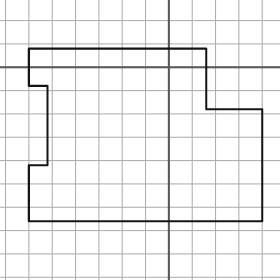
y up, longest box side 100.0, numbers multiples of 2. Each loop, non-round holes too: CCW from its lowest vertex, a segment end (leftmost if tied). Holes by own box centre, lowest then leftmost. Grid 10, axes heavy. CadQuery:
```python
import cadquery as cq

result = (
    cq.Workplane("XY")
    .moveTo(-60.0, -66.0)
    .lineTo(40.0, -66.0)
    .lineTo(40.0, -18.0)
    .lineTo(16.0, -18.0)
    .lineTo(16.0, 8.0)
    .lineTo(-60.0, 8.0)
    .lineTo(-60.0, -8.0)
    .lineTo(-52.0, -8.0)
    .lineTo(-52.0, -42.0)
    .lineTo(-60.0, -42.0)
    .close()
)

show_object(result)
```